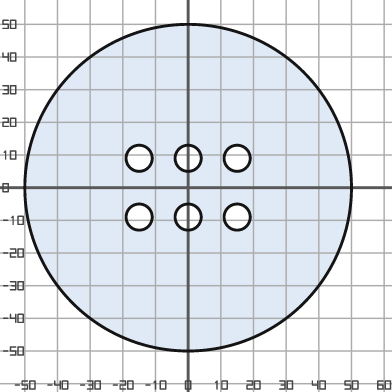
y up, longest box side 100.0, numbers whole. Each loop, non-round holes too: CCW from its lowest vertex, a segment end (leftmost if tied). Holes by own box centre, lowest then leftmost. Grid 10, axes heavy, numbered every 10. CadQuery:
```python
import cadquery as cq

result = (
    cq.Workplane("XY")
    .moveTo(0.0, 0.0)
    .circle(50.0)
    .moveTo(-15.0, -9.0)
    .circle(4.0)
    .moveTo(0.0, -9.0)
    .circle(4.0)
    .moveTo(15.0, -9.0)
    .circle(4.0)
    .moveTo(-15.0, 9.0)
    .circle(4.0)
    .moveTo(0.0, 9.0)
    .circle(4.0)
    .moveTo(15.0, 9.0)
    .circle(4.0)
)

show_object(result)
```